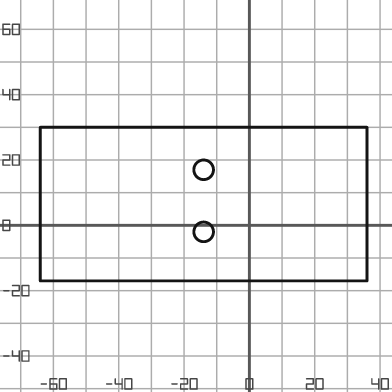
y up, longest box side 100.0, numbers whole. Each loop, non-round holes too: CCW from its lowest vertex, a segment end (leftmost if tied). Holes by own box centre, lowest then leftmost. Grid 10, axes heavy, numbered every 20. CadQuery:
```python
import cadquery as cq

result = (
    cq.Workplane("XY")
    .moveTo(-64.0, -17.0)
    .lineTo(36.0, -17.0)
    .lineTo(36.0, 30.0)
    .lineTo(-64.0, 30.0)
    .close()
    .moveTo(-14.0, -2.0)
    .circle(3.0)
    .moveTo(-14.0, 17.0)
    .circle(3.0)
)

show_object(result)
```